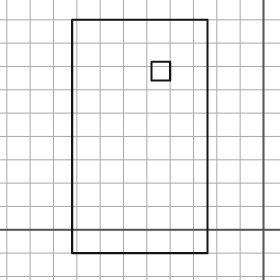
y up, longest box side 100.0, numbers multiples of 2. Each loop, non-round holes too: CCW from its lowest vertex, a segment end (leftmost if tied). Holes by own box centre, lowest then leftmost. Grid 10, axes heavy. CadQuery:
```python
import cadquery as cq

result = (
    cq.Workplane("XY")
    .moveTo(-82.0, -10.0)
    .lineTo(-24.0, -10.0)
    .lineTo(-24.0, 90.0)
    .lineTo(-82.0, 90.0)
    .close()
    .moveTo(-48.0, 64.0)
    .lineTo(-40.0, 64.0)
    .lineTo(-40.0, 72.0)
    .lineTo(-48.0, 72.0)
    .close()
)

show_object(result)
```